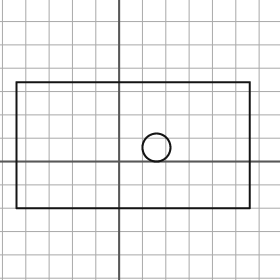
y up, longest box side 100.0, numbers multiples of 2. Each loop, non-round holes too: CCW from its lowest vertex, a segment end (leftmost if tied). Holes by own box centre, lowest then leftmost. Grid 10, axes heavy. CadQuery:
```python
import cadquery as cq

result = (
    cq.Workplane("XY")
    .moveTo(-44.0, -20.0)
    .lineTo(56.0, -20.0)
    .lineTo(56.0, 34.0)
    .lineTo(-44.0, 34.0)
    .close()
    .moveTo(16.0, 6.0)
    .circle(6.0)
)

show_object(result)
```